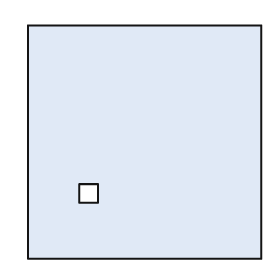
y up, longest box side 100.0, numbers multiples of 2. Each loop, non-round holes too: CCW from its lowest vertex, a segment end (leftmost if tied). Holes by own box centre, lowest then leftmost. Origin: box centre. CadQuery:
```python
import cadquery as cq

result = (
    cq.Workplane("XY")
    .moveTo(-50.0, -50.0)
    .lineTo(50.0, -50.0)
    .lineTo(50.0, 50.0)
    .lineTo(-50.0, 50.0)
    .close()
    .moveTo(-28.0, -26.0)
    .lineTo(-20.0, -26.0)
    .lineTo(-20.0, -18.0)
    .lineTo(-28.0, -18.0)
    .close()
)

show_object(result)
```